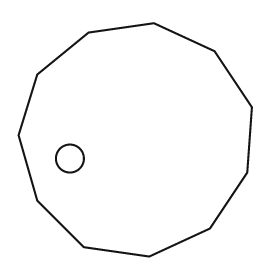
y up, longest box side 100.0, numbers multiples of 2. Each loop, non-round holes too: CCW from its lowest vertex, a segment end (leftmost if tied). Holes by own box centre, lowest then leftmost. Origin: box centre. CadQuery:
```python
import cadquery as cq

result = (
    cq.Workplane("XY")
    .moveTo(6.0, -50.0)
    .lineTo(32.0, -38.0)
    .lineTo(48.0, -14.0)
    .lineTo(50.0, 14.0)
    .lineTo(34.0, 38.0)
    .lineTo(8.0, 50.0)
    .lineTo(-20.0, 46.0)
    .lineTo(-42.0, 28.0)
    .lineTo(-50.0, 2.0)
    .lineTo(-42.0, -26.0)
    .lineTo(-22.0, -46.0)
    .close()
    .moveTo(-28.0, -8.0)
    .circle(6.0)
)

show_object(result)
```